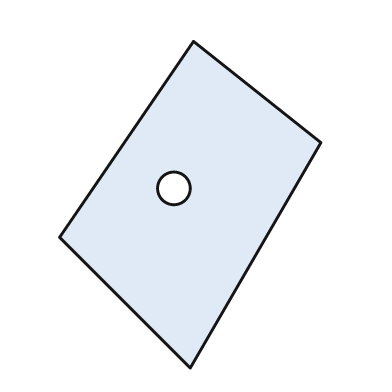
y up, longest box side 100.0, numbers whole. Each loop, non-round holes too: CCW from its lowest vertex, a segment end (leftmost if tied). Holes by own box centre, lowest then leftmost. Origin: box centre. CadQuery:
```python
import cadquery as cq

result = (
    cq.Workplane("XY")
    .moveTo(0.0, -50.0)
    .lineTo(40.0, 19.0)
    .lineTo(1.0, 50.0)
    .lineTo(-40.0, -10.0)
    .close()
    .moveTo(-5.0, 5.0)
    .circle(5.0)
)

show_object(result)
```